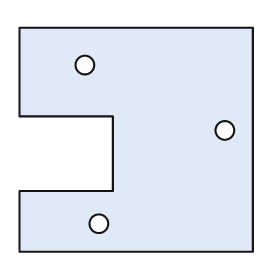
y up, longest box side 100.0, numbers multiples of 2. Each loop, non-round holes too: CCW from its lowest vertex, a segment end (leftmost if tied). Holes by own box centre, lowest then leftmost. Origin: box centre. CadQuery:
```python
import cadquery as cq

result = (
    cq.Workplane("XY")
    .moveTo(-50.0, -48.0)
    .lineTo(50.0, -48.0)
    .lineTo(50.0, 48.0)
    .lineTo(-50.0, 48.0)
    .lineTo(-50.0, 10.0)
    .lineTo(-10.0, 10.0)
    .lineTo(-10.0, -22.0)
    .lineTo(-50.0, -22.0)
    .close()
    .moveTo(-16.0, -36.0)
    .circle(4.0)
    .moveTo(38.0, 4.0)
    .circle(4.0)
    .moveTo(-22.0, 32.0)
    .circle(4.0)
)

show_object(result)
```